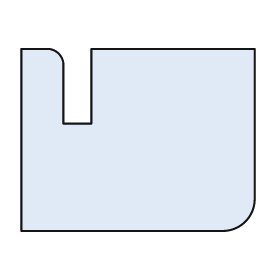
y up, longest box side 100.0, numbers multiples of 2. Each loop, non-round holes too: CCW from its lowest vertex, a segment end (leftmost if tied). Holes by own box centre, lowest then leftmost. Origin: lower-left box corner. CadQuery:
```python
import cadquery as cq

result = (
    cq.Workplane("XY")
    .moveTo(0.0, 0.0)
    .lineTo(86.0, 0.0)
    .threePointArc((96.0, 4.0), (100.0, 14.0))
    .lineTo(100.0, 78.0)
    .lineTo(30.0, 78.0)
    .lineTo(30.0, 46.0)
    .lineTo(18.0, 46.0)
    .lineTo(18.0, 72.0)
    .threePointArc((16.0, 76.0), (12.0, 78.0))
    .lineTo(0.0, 78.0)
    .close()
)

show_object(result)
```